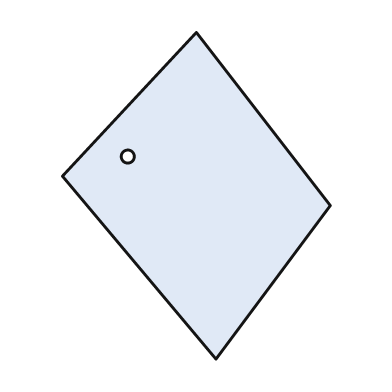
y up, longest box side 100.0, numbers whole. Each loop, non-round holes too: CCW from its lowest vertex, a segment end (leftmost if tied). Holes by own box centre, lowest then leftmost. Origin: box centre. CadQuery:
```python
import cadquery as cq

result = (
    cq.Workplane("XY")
    .moveTo(6.0, -50.0)
    .lineTo(41.0, -3.0)
    .lineTo(0.0, 50.0)
    .lineTo(-41.0, 6.0)
    .close()
    .moveTo(-21.0, 12.0)
    .circle(2.0)
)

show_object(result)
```